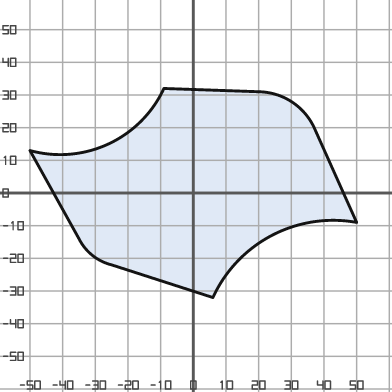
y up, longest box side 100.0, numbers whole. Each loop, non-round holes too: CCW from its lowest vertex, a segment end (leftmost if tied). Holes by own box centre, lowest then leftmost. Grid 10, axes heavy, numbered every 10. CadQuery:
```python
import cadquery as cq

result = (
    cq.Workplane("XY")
    .moveTo(6.0, -32.0)
    .threePointArc((24.0, -13.0), (50.0, -9.0))
    .lineTo(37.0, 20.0)
    .threePointArc((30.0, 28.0), (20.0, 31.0))
    .lineTo(-9.0, 32.0)
    .threePointArc((-26.0, 15.0), (-50.0, 13.0))
    .lineTo(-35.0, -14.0)
    .threePointArc((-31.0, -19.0), (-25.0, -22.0))
    .close()
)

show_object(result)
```